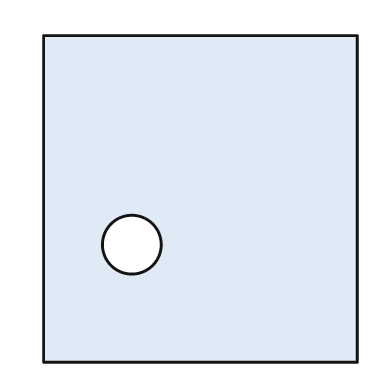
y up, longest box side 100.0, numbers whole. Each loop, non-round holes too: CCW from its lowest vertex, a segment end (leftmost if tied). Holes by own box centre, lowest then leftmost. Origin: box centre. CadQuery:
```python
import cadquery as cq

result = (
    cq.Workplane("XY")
    .moveTo(-48.0, -50.0)
    .lineTo(48.0, -50.0)
    .lineTo(48.0, 50.0)
    .lineTo(-48.0, 50.0)
    .close()
    .moveTo(-21.0, -14.0)
    .circle(9.0)
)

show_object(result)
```